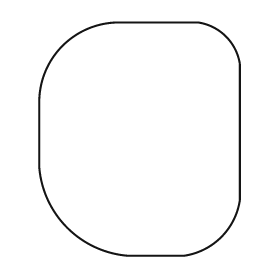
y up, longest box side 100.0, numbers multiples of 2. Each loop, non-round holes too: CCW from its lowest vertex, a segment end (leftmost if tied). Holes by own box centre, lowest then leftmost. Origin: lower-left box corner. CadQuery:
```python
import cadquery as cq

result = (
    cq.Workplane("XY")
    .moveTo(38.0, 0.0)
    .lineTo(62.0, 0.0)
    .threePointArc((78.0, 8.0), (86.0, 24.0))
    .lineTo(86.0, 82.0)
    .threePointArc((80.0, 94.0), (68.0, 100.0))
    .lineTo(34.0, 100.0)
    .threePointArc((10.0, 90.0), (0.0, 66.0))
    .lineTo(0.0, 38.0)
    .threePointArc((12.0, 12.0), (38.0, 0.0))
    .close()
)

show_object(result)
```